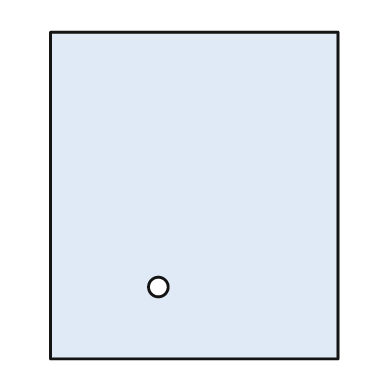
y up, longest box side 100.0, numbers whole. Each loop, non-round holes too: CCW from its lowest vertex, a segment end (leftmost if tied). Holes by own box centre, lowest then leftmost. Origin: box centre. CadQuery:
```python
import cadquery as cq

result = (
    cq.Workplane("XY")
    .moveTo(-44.0, -50.0)
    .lineTo(44.0, -50.0)
    .lineTo(44.0, 50.0)
    .lineTo(-44.0, 50.0)
    .close()
    .moveTo(-11.0, -28.0)
    .circle(3.0)
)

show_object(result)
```